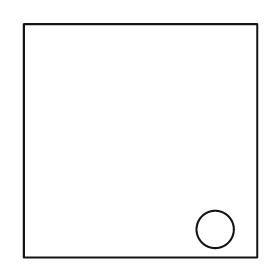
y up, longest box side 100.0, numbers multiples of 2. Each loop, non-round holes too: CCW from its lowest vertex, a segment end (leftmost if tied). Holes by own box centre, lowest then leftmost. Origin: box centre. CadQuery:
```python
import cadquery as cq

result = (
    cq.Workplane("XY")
    .moveTo(-50.0, -50.0)
    .lineTo(50.0, -50.0)
    .lineTo(50.0, 50.0)
    .lineTo(-50.0, 50.0)
    .close()
    .moveTo(32.0, -38.0)
    .circle(8.0)
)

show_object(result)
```